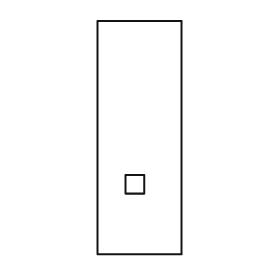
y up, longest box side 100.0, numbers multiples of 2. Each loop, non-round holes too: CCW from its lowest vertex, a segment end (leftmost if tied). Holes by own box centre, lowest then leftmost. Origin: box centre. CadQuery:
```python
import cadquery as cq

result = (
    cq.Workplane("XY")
    .moveTo(-18.0, -50.0)
    .lineTo(18.0, -50.0)
    .lineTo(18.0, 50.0)
    .lineTo(-18.0, 50.0)
    .close()
    .moveTo(-6.0, -24.0)
    .lineTo(2.0, -24.0)
    .lineTo(2.0, -16.0)
    .lineTo(-6.0, -16.0)
    .close()
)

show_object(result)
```